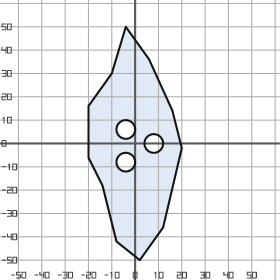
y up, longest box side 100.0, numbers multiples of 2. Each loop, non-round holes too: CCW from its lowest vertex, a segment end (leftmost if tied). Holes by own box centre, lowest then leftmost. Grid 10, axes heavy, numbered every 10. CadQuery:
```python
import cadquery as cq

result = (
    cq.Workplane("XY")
    .moveTo(2.0, -50.0)
    .lineTo(12.0, -36.0)
    .lineTo(20.0, -2.0)
    .lineTo(16.0, 14.0)
    .lineTo(6.0, 36.0)
    .lineTo(-4.0, 50.0)
    .lineTo(-10.0, 30.0)
    .lineTo(-20.0, 16.0)
    .lineTo(-20.0, -6.0)
    .lineTo(-14.0, -18.0)
    .lineTo(-8.0, -42.0)
    .close()
    .moveTo(-4.0, -8.0)
    .circle(4.0)
    .moveTo(8.0, 0.0)
    .circle(4.0)
    .moveTo(-4.0, 6.0)
    .circle(4.0)
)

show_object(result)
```